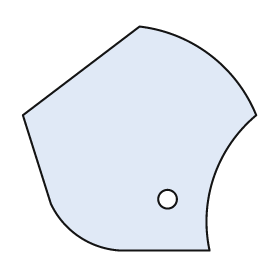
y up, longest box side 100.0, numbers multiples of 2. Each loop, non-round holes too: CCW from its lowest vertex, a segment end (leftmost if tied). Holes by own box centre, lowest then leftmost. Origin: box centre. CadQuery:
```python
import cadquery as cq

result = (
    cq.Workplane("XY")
    .moveTo(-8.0, -48.0)
    .lineTo(30.0, -48.0)
    .threePointArc((32.0, -16.0), (50.0, 10.0))
    .threePointArc((30.0, 36.0), (0.0, 48.0))
    .lineTo(-50.0, 10.0)
    .lineTo(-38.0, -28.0)
    .threePointArc((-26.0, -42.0), (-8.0, -48.0))
    .close()
    .moveTo(12.0, -26.0)
    .circle(4.0)
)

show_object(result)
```